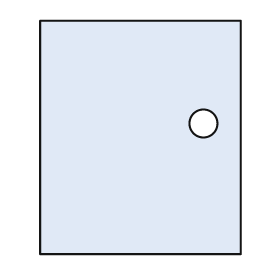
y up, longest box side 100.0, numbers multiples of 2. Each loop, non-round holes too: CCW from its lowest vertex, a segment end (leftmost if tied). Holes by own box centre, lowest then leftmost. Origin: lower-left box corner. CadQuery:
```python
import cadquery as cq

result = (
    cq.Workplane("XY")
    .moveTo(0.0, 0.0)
    .lineTo(86.0, 0.0)
    .lineTo(86.0, 100.0)
    .lineTo(0.0, 100.0)
    .close()
    .moveTo(70.0, 56.0)
    .circle(6.0)
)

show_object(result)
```